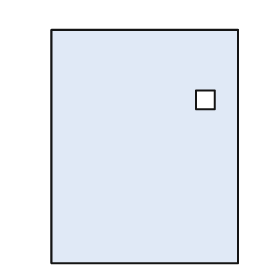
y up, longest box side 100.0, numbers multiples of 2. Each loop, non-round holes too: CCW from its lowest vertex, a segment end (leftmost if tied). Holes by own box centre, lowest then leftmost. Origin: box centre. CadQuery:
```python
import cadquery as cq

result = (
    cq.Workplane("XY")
    .moveTo(-40.0, -50.0)
    .lineTo(40.0, -50.0)
    .lineTo(40.0, 50.0)
    .lineTo(-40.0, 50.0)
    .close()
    .moveTo(22.0, 16.0)
    .lineTo(30.0, 16.0)
    .lineTo(30.0, 24.0)
    .lineTo(22.0, 24.0)
    .close()
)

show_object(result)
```